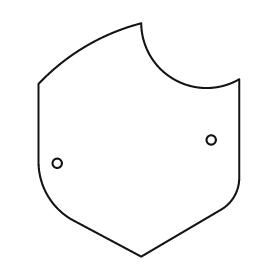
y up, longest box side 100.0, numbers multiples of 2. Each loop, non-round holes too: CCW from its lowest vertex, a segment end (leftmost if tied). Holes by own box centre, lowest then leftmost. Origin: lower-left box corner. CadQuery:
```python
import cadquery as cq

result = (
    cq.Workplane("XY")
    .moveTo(44.0, 0.0)
    .lineTo(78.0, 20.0)
    .threePointArc((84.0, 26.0), (86.0, 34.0))
    .lineTo(86.0, 76.0)
    .threePointArc((58.0, 76.0), (44.0, 100.0))
    .threePointArc((20.0, 90.0), (0.0, 74.0))
    .lineTo(0.0, 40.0)
    .threePointArc((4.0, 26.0), (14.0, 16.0))
    .close()
    .moveTo(8.0, 40.0)
    .circle(2.0)
    .moveTo(74.0, 50.0)
    .circle(2.0)
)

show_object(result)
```